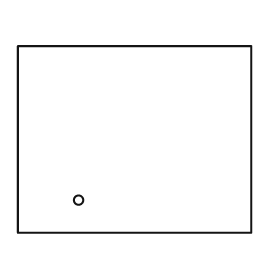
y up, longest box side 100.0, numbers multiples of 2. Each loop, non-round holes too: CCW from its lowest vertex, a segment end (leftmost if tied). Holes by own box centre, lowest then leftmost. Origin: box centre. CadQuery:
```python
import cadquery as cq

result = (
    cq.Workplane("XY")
    .moveTo(-50.0, -40.0)
    .lineTo(50.0, -40.0)
    .lineTo(50.0, 40.0)
    .lineTo(-50.0, 40.0)
    .close()
    .moveTo(-24.0, -26.0)
    .circle(2.0)
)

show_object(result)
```